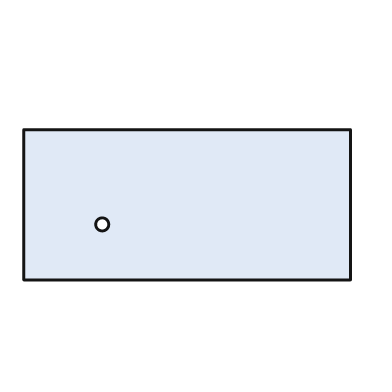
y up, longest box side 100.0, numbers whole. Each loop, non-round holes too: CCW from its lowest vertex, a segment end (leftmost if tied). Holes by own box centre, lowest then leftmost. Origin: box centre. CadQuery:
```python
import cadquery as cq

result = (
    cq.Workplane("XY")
    .moveTo(-50.0, -23.0)
    .lineTo(50.0, -23.0)
    .lineTo(50.0, 23.0)
    .lineTo(-50.0, 23.0)
    .close()
    .moveTo(-26.0, -6.0)
    .circle(2.0)
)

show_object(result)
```